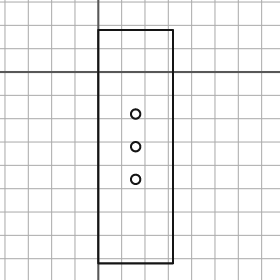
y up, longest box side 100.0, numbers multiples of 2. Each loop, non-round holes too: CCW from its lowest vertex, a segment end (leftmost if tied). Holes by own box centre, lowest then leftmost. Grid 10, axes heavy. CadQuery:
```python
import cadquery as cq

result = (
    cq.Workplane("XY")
    .moveTo(0.0, -82.0)
    .lineTo(32.0, -82.0)
    .lineTo(32.0, 18.0)
    .lineTo(0.0, 18.0)
    .close()
    .moveTo(16.0, -46.0)
    .circle(2.0)
    .moveTo(16.0, -32.0)
    .circle(2.0)
    .moveTo(16.0, -18.0)
    .circle(2.0)
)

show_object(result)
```